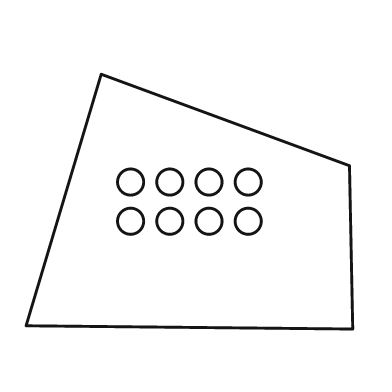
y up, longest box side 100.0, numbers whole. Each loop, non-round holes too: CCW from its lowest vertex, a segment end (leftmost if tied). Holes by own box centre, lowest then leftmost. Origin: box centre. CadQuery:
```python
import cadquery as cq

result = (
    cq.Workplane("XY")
    .moveTo(50.0, -39.0)
    .lineTo(49.0, 11.0)
    .lineTo(-27.0, 39.0)
    .lineTo(-50.0, -38.0)
    .close()
    .moveTo(-18.0, -6.0)
    .circle(4.0)
    .moveTo(-6.0, -6.0)
    .circle(4.0)
    .moveTo(6.0, -6.0)
    .circle(4.0)
    .moveTo(18.0, -6.0)
    .circle(4.0)
    .moveTo(-18.0, 6.0)
    .circle(4.0)
    .moveTo(-6.0, 6.0)
    .circle(4.0)
    .moveTo(6.0, 6.0)
    .circle(4.0)
    .moveTo(18.0, 6.0)
    .circle(4.0)
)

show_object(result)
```